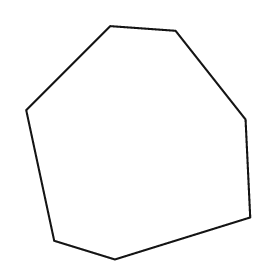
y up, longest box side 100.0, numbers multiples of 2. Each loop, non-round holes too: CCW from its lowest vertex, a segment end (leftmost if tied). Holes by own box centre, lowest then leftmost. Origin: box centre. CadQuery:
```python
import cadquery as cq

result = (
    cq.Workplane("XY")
    .moveTo(-10.0, -50.0)
    .lineTo(48.0, -32.0)
    .lineTo(46.0, 10.0)
    .lineTo(16.0, 48.0)
    .lineTo(-12.0, 50.0)
    .lineTo(-48.0, 14.0)
    .lineTo(-36.0, -42.0)
    .close()
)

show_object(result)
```